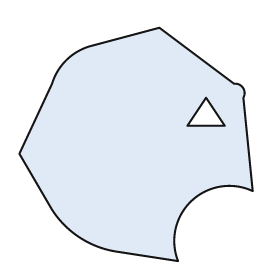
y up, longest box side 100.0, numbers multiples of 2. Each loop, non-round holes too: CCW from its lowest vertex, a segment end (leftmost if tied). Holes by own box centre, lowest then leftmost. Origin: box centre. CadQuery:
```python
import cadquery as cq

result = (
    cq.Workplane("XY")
    .moveTo(18.0, -50.0)
    .threePointArc((24.0, -24.0), (50.0, -20.0))
    .lineTo(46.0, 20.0)
    .threePointArc((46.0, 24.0), (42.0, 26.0))
    .lineTo(10.0, 50.0)
    .lineTo(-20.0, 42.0)
    .threePointArc((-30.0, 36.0), (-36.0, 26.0))
    .lineTo(-50.0, -4.0)
    .lineTo(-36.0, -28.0)
    .threePointArc((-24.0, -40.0), (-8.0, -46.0))
    .close()
    .moveTo(22.0, 8.0)
    .lineTo(38.0, 8.0)
    .lineTo(30.0, 20.0)
    .close()
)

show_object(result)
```